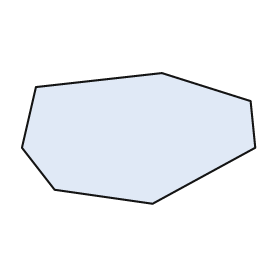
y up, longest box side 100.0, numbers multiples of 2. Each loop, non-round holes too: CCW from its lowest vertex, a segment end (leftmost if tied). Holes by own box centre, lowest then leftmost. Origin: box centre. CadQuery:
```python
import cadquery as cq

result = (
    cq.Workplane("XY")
    .moveTo(6.0, -28.0)
    .lineTo(50.0, -4.0)
    .lineTo(48.0, 16.0)
    .lineTo(10.0, 28.0)
    .lineTo(-44.0, 22.0)
    .lineTo(-50.0, -4.0)
    .lineTo(-36.0, -22.0)
    .close()
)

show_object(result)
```